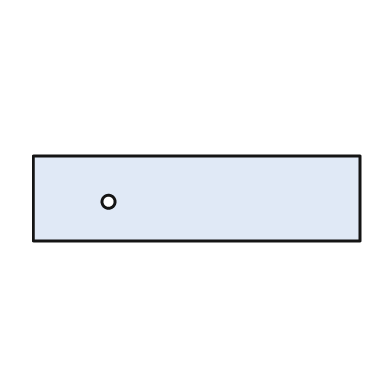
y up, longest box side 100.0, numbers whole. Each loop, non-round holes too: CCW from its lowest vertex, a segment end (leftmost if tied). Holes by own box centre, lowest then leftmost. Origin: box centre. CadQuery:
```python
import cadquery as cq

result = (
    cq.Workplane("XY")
    .moveTo(-50.0, -13.0)
    .lineTo(50.0, -13.0)
    .lineTo(50.0, 13.0)
    .lineTo(-50.0, 13.0)
    .close()
    .moveTo(-27.0, -1.0)
    .circle(2.0)
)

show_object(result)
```